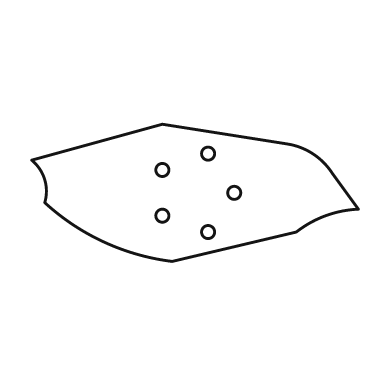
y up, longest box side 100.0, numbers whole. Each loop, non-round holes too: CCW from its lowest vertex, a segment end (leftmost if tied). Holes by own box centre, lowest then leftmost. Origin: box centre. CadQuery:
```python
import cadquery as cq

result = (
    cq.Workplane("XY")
    .moveTo(-7.0, -21.0)
    .lineTo(31.0, -12.0)
    .threePointArc((40.0, -7.0), (50.0, -5.0))
    .lineTo(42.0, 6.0)
    .threePointArc((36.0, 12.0), (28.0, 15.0))
    .lineTo(-10.0, 21.0)
    .lineTo(-50.0, 10.0)
    .threePointArc((-46.0, 4.0), (-46.0, -3.0))
    .threePointArc((-28.0, -15.0), (-7.0, -21.0))
    .close()
    .moveTo(4.0, -12.0)
    .circle(2.0)
    .moveTo(-10.0, -7.0)
    .circle(2.0)
    .moveTo(12.0, 0.0)
    .circle(2.0)
    .moveTo(-10.0, 7.0)
    .circle(2.0)
    .moveTo(4.0, 12.0)
    .circle(2.0)
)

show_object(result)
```